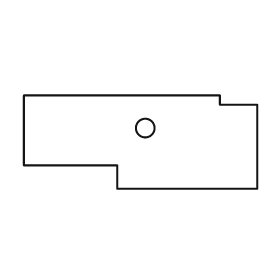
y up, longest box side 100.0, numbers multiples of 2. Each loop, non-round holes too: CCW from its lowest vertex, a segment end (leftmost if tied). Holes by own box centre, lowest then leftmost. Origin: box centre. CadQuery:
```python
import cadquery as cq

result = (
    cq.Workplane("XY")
    .moveTo(-10.0, -20.0)
    .lineTo(50.0, -20.0)
    .lineTo(50.0, 16.0)
    .lineTo(34.0, 16.0)
    .lineTo(34.0, 20.0)
    .lineTo(-50.0, 20.0)
    .lineTo(-50.0, -10.0)
    .lineTo(-10.0, -10.0)
    .close()
    .moveTo(2.0, 6.0)
    .circle(4.0)
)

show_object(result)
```